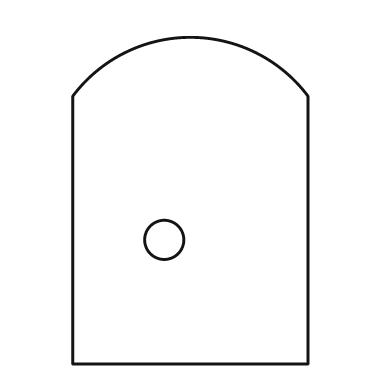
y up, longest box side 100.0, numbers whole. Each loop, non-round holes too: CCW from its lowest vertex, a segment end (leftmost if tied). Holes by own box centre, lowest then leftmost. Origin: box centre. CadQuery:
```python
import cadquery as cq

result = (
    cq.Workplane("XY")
    .moveTo(-36.0, -50.0)
    .lineTo(36.0, -50.0)
    .lineTo(36.0, 32.0)
    .threePointArc((0.0, 50.0), (-36.0, 32.0))
    .close()
    .moveTo(-8.0, -12.0)
    .circle(6.0)
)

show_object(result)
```